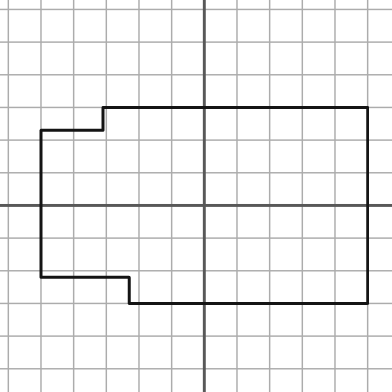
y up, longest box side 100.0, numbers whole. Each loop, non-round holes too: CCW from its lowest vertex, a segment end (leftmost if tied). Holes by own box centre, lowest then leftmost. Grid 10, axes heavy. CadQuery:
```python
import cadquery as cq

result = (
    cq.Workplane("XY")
    .moveTo(-23.0, -30.0)
    .lineTo(50.0, -30.0)
    .lineTo(50.0, 30.0)
    .lineTo(-31.0, 30.0)
    .lineTo(-31.0, 23.0)
    .lineTo(-50.0, 23.0)
    .lineTo(-50.0, -22.0)
    .lineTo(-23.0, -22.0)
    .close()
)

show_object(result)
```